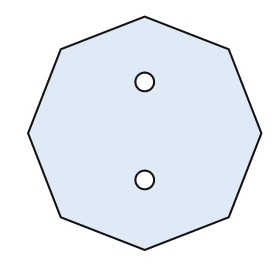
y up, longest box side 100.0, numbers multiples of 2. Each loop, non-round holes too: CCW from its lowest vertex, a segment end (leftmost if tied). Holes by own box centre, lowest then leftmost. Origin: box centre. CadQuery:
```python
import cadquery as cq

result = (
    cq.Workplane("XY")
    .moveTo(0.0, -50.0)
    .lineTo(36.0, -36.0)
    .lineTo(50.0, 0.0)
    .lineTo(36.0, 36.0)
    .lineTo(0.0, 50.0)
    .lineTo(-36.0, 36.0)
    .lineTo(-50.0, 0.0)
    .lineTo(-36.0, -36.0)
    .close()
    .moveTo(0.0, -20.0)
    .circle(4.0)
    .moveTo(0.0, 22.0)
    .circle(4.0)
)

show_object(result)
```